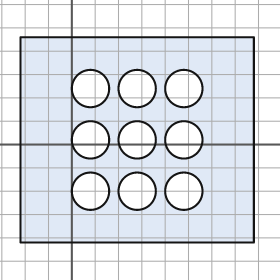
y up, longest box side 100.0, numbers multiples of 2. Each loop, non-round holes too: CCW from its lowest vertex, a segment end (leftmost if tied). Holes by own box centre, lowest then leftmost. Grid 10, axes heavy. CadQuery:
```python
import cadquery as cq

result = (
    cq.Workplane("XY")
    .moveTo(-22.0, -42.0)
    .lineTo(78.0, -42.0)
    .lineTo(78.0, 46.0)
    .lineTo(-22.0, 46.0)
    .close()
    .moveTo(8.0, -20.0)
    .circle(8.0)
    .moveTo(28.0, -20.0)
    .circle(8.0)
    .moveTo(48.0, -20.0)
    .circle(8.0)
    .moveTo(8.0, 2.0)
    .circle(8.0)
    .moveTo(28.0, 2.0)
    .circle(8.0)
    .moveTo(48.0, 2.0)
    .circle(8.0)
    .moveTo(8.0, 24.0)
    .circle(8.0)
    .moveTo(28.0, 24.0)
    .circle(8.0)
    .moveTo(48.0, 24.0)
    .circle(8.0)
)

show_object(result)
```